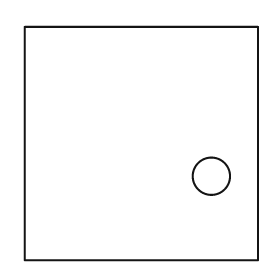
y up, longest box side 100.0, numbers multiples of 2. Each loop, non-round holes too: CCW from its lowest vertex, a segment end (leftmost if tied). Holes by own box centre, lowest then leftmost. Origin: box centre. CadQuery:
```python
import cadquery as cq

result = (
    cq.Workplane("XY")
    .moveTo(-50.0, -50.0)
    .lineTo(50.0, -50.0)
    .lineTo(50.0, 50.0)
    .lineTo(-50.0, 50.0)
    .close()
    .moveTo(30.0, -14.0)
    .circle(8.0)
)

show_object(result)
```